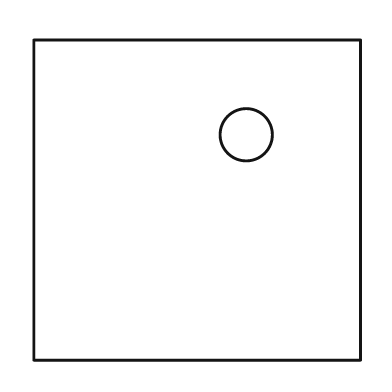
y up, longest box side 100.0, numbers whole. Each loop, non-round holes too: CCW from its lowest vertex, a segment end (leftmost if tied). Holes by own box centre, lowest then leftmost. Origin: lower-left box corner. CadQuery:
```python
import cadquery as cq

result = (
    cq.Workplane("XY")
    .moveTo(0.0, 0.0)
    .lineTo(100.0, 0.0)
    .lineTo(100.0, 98.0)
    .lineTo(0.0, 98.0)
    .close()
    .moveTo(65.0, 69.0)
    .circle(8.0)
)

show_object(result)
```